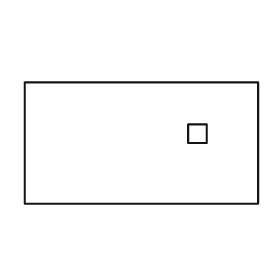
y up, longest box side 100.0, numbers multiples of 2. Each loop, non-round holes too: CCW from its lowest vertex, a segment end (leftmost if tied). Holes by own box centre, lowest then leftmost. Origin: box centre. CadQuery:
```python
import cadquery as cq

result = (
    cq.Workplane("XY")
    .moveTo(-50.0, -26.0)
    .lineTo(50.0, -26.0)
    .lineTo(50.0, 26.0)
    .lineTo(-50.0, 26.0)
    .close()
    .moveTo(20.0, 0.0)
    .lineTo(28.0, 0.0)
    .lineTo(28.0, 8.0)
    .lineTo(20.0, 8.0)
    .close()
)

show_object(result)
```